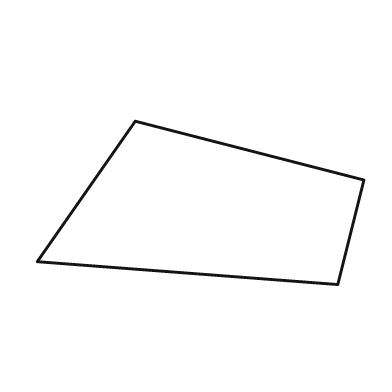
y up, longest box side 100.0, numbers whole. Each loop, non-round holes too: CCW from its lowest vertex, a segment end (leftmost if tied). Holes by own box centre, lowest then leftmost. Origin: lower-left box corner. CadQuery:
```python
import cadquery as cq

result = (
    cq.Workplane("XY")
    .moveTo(92.0, 0.0)
    .lineTo(100.0, 32.0)
    .lineTo(30.0, 50.0)
    .lineTo(0.0, 7.0)
    .close()
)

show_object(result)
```